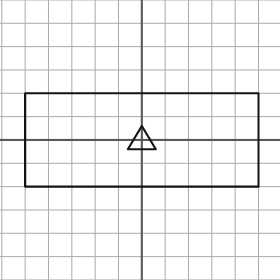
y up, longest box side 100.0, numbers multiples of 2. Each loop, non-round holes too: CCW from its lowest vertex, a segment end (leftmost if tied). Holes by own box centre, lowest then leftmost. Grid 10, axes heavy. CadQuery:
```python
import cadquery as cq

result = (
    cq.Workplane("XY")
    .moveTo(-50.0, -20.0)
    .lineTo(50.0, -20.0)
    .lineTo(50.0, 20.0)
    .lineTo(-50.0, 20.0)
    .close()
    .moveTo(-6.0, -4.0)
    .lineTo(6.0, -4.0)
    .lineTo(0.0, 6.0)
    .close()
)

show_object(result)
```